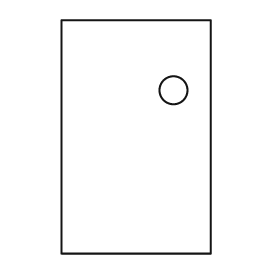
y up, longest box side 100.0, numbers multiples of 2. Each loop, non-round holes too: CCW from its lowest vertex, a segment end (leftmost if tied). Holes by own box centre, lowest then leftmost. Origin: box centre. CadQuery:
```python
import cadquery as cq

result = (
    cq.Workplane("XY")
    .moveTo(-32.0, -50.0)
    .lineTo(32.0, -50.0)
    .lineTo(32.0, 50.0)
    .lineTo(-32.0, 50.0)
    .close()
    .moveTo(16.0, 20.0)
    .circle(6.0)
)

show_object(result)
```